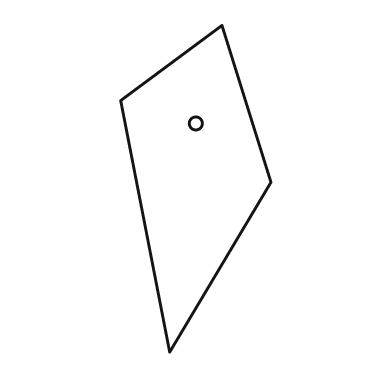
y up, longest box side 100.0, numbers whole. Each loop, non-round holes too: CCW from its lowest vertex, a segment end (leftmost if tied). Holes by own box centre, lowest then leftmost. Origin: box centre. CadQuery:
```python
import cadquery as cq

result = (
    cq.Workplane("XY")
    .moveTo(-8.0, -50.0)
    .lineTo(23.0, 2.0)
    .lineTo(8.0, 50.0)
    .lineTo(-23.0, 27.0)
    .close()
    .moveTo(0.0, 20.0)
    .circle(2.0)
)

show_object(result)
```